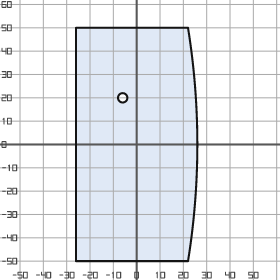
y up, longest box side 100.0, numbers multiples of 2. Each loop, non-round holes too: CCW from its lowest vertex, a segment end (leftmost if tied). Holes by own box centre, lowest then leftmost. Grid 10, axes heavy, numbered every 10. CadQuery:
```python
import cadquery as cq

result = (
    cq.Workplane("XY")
    .moveTo(-26.0, -50.0)
    .lineTo(22.0, -50.0)
    .threePointArc((26.0, 0.0), (22.0, 50.0))
    .lineTo(-26.0, 50.0)
    .close()
    .moveTo(-6.0, 20.0)
    .circle(2.0)
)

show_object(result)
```